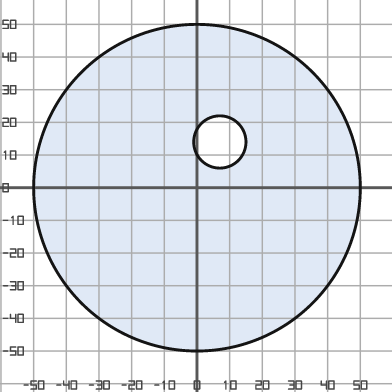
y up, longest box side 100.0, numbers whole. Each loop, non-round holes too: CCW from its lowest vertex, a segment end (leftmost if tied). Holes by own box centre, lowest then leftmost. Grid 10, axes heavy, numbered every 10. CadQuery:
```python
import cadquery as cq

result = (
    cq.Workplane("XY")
    .moveTo(0.0, 0.0)
    .circle(50.0)
    .moveTo(7.0, 14.0)
    .circle(8.0)
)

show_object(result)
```